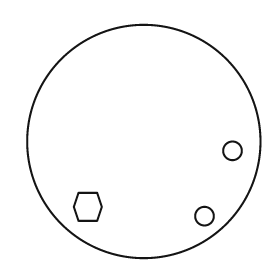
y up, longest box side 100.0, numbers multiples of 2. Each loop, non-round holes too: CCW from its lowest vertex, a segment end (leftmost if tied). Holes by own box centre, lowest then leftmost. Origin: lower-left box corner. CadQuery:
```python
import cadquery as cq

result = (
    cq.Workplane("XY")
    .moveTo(50.0, 50.0)
    .circle(50.0)
    .moveTo(76.0, 18.0)
    .circle(4.0)
    .moveTo(22.0, 16.0)
    .lineTo(30.0, 16.0)
    .lineTo(32.0, 22.0)
    .lineTo(30.0, 28.0)
    .lineTo(22.0, 28.0)
    .lineTo(20.0, 22.0)
    .close()
    .moveTo(88.0, 46.0)
    .circle(4.0)
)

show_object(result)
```